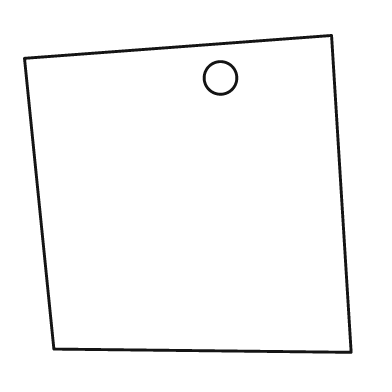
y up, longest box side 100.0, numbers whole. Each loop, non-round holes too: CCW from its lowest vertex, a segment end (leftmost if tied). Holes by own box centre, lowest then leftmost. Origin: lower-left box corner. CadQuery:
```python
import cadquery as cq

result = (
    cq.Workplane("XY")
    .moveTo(100.0, 0.0)
    .lineTo(94.0, 97.0)
    .lineTo(0.0, 90.0)
    .lineTo(9.0, 1.0)
    .close()
    .moveTo(60.0, 84.0)
    .circle(5.0)
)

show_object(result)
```